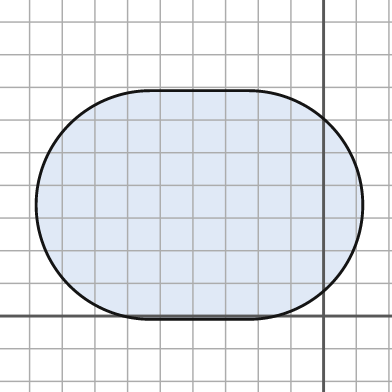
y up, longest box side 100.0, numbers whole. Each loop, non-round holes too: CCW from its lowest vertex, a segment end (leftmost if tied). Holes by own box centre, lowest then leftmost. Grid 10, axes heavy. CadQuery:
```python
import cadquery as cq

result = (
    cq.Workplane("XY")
    .moveTo(-53.0, -1.0)
    .lineTo(-23.0, -1.0)
    .threePointArc((12.0, 34.0), (-23.0, 69.0))
    .lineTo(-53.0, 69.0)
    .threePointArc((-88.0, 34.0), (-53.0, -1.0))
    .close()
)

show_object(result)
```